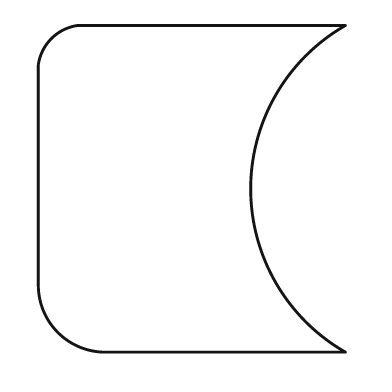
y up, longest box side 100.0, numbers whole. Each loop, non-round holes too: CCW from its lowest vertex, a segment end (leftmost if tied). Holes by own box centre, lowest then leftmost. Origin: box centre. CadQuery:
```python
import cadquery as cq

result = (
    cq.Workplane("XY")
    .moveTo(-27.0, -50.0)
    .lineTo(47.0, -50.0)
    .threePointArc((18.0, 0.0), (47.0, 50.0))
    .lineTo(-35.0, 50.0)
    .threePointArc((-43.0, 46.0), (-47.0, 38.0))
    .lineTo(-47.0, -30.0)
    .threePointArc((-41.0, -44.0), (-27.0, -50.0))
    .close()
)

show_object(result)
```